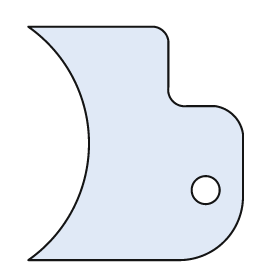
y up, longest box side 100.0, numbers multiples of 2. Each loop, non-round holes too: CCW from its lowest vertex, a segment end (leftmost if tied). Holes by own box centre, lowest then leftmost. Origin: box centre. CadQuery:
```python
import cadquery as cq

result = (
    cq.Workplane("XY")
    .moveTo(-46.0, -50.0)
    .lineTo(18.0, -50.0)
    .threePointArc((38.0, -42.0), (46.0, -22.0))
    .lineTo(46.0, 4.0)
    .threePointArc((42.0, 12.0), (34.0, 16.0))
    .lineTo(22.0, 16.0)
    .threePointArc((16.0, 18.0), (14.0, 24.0))
    .lineTo(14.0, 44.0)
    .threePointArc((12.0, 48.0), (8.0, 50.0))
    .lineTo(-46.0, 50.0)
    .threePointArc((-20.0, 0.0), (-46.0, -50.0))
    .close()
    .moveTo(30.0, -20.0)
    .circle(6.0)
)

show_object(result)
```